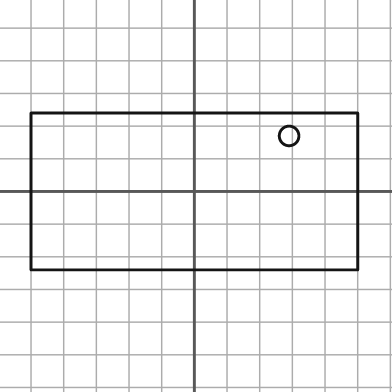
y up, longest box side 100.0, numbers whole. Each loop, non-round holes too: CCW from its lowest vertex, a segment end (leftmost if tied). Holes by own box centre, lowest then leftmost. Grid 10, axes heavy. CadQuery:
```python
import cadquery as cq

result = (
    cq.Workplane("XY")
    .moveTo(-50.0, -24.0)
    .lineTo(50.0, -24.0)
    .lineTo(50.0, 24.0)
    .lineTo(-50.0, 24.0)
    .close()
    .moveTo(29.0, 17.0)
    .circle(3.0)
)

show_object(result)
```